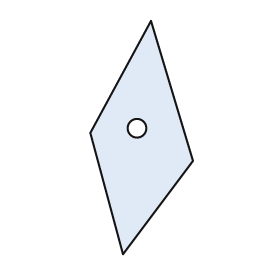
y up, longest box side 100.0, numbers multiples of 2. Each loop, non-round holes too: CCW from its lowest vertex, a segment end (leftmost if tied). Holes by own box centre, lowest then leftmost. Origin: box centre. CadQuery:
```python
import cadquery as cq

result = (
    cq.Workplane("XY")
    .moveTo(-8.0, -50.0)
    .lineTo(22.0, -10.0)
    .lineTo(4.0, 50.0)
    .lineTo(-22.0, 2.0)
    .close()
    .moveTo(-2.0, 4.0)
    .circle(4.0)
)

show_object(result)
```